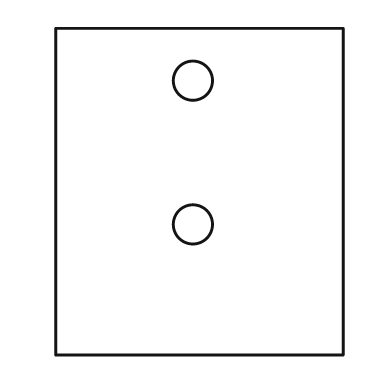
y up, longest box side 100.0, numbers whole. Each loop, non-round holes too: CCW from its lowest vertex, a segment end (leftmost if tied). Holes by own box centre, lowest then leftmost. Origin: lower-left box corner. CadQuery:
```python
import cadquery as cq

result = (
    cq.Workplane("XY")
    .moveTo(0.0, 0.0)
    .lineTo(88.0, 0.0)
    .lineTo(88.0, 100.0)
    .lineTo(0.0, 100.0)
    .close()
    .moveTo(42.0, 40.0)
    .circle(6.0)
    .moveTo(42.0, 84.0)
    .circle(6.0)
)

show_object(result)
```